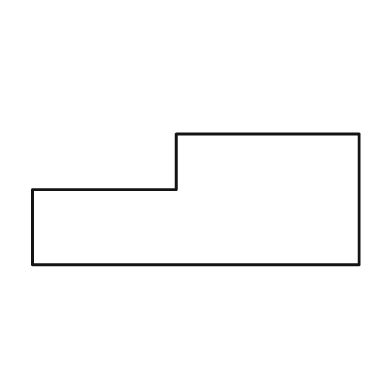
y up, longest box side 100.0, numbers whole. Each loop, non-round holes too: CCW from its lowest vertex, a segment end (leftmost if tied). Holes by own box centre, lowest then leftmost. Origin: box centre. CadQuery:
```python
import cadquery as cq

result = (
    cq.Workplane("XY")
    .moveTo(-50.0, -20.0)
    .lineTo(50.0, -20.0)
    .lineTo(50.0, 20.0)
    .lineTo(-6.0, 20.0)
    .lineTo(-6.0, 3.0)
    .lineTo(-50.0, 3.0)
    .close()
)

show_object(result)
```